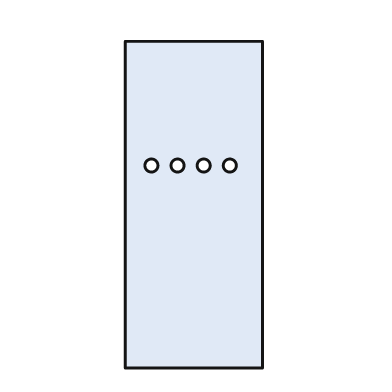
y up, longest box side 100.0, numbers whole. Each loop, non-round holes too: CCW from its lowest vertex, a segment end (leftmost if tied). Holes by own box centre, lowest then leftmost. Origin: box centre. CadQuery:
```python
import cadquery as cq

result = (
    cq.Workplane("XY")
    .moveTo(-21.0, -50.0)
    .lineTo(21.0, -50.0)
    .lineTo(21.0, 50.0)
    .lineTo(-21.0, 50.0)
    .close()
    .moveTo(-13.0, 12.0)
    .circle(2.0)
    .moveTo(-5.0, 12.0)
    .circle(2.0)
    .moveTo(3.0, 12.0)
    .circle(2.0)
    .moveTo(11.0, 12.0)
    .circle(2.0)
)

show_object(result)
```